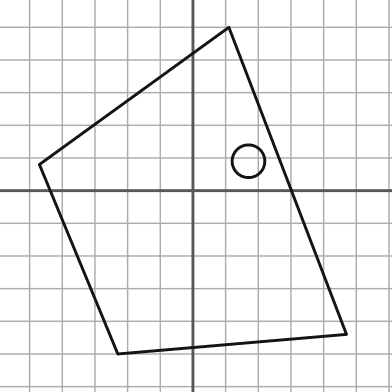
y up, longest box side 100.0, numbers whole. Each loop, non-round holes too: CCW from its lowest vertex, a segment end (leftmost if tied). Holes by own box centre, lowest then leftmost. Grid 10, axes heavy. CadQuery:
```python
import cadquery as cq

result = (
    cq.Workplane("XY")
    .moveTo(-23.0, -50.0)
    .lineTo(47.0, -44.0)
    .lineTo(11.0, 50.0)
    .lineTo(-47.0, 8.0)
    .close()
    .moveTo(17.0, 9.0)
    .circle(5.0)
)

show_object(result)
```